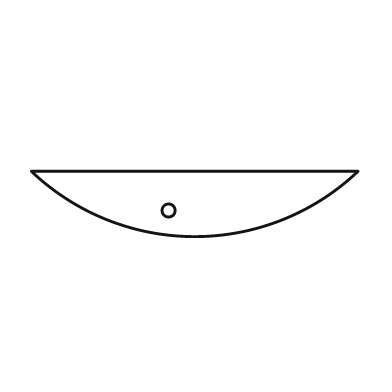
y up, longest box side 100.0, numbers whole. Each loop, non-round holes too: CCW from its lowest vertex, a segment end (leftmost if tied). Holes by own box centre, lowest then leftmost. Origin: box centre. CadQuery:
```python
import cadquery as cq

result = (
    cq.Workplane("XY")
    .moveTo(-50.0, 10.0)
    .threePointArc((0.0, -10.0), (50.0, 10.0))
    .close()
    .moveTo(-8.0, -2.0)
    .circle(2.0)
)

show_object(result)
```